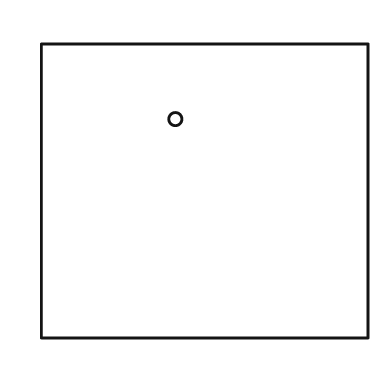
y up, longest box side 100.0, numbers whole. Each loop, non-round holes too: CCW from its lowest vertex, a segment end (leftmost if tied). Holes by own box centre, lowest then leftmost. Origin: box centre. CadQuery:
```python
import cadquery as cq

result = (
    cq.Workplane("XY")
    .moveTo(-50.0, -45.0)
    .lineTo(50.0, -45.0)
    .lineTo(50.0, 45.0)
    .lineTo(-50.0, 45.0)
    .close()
    .moveTo(-9.0, 22.0)
    .circle(2.0)
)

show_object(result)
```